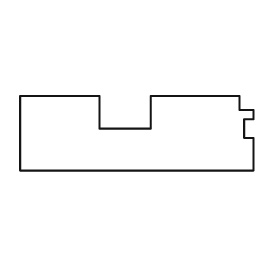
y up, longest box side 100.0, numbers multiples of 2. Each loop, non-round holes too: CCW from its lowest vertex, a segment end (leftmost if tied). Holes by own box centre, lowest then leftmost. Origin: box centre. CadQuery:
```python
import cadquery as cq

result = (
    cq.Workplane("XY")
    .moveTo(-50.0, -16.0)
    .lineTo(50.0, -16.0)
    .lineTo(50.0, -2.0)
    .lineTo(46.0, -2.0)
    .lineTo(46.0, 6.0)
    .lineTo(50.0, 6.0)
    .lineTo(50.0, 10.0)
    .lineTo(44.0, 10.0)
    .lineTo(44.0, 16.0)
    .lineTo(6.0, 16.0)
    .lineTo(6.0, 2.0)
    .lineTo(-16.0, 2.0)
    .lineTo(-16.0, 16.0)
    .lineTo(-50.0, 16.0)
    .close()
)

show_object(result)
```